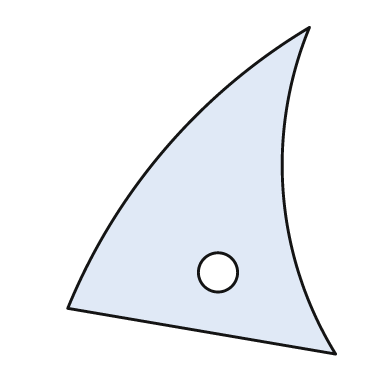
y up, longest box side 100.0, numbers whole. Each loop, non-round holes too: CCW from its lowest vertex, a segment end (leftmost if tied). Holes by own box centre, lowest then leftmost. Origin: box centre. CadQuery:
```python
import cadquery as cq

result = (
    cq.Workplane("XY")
    .moveTo(41.0, -50.0)
    .threePointArc((25.0, -1.0), (33.0, 50.0))
    .threePointArc((-11.0, 13.0), (-41.0, -36.0))
    .close()
    .moveTo(5.0, -25.0)
    .circle(6.0)
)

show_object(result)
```